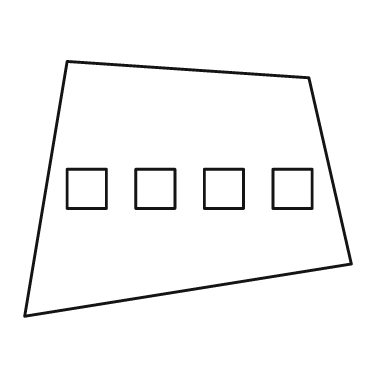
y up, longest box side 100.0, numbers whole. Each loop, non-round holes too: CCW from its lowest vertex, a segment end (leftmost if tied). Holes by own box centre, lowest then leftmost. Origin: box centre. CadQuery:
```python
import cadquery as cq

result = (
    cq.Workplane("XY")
    .moveTo(-50.0, -39.0)
    .lineTo(50.0, -23.0)
    .lineTo(37.0, 34.0)
    .lineTo(-37.0, 39.0)
    .close()
    .moveTo(-37.0, -6.0)
    .lineTo(-25.0, -6.0)
    .lineTo(-25.0, 6.0)
    .lineTo(-37.0, 6.0)
    .close()
    .moveTo(-16.0, -6.0)
    .lineTo(-4.0, -6.0)
    .lineTo(-4.0, 6.0)
    .lineTo(-16.0, 6.0)
    .close()
    .moveTo(5.0, -6.0)
    .lineTo(17.0, -6.0)
    .lineTo(17.0, 6.0)
    .lineTo(5.0, 6.0)
    .close()
    .moveTo(26.0, -6.0)
    .lineTo(38.0, -6.0)
    .lineTo(38.0, 6.0)
    .lineTo(26.0, 6.0)
    .close()
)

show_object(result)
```